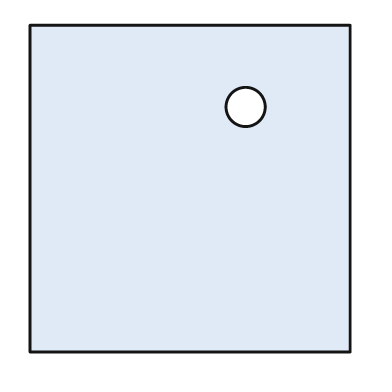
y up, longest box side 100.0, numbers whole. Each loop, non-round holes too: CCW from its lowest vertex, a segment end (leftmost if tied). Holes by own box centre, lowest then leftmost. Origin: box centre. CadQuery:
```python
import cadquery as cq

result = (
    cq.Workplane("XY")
    .moveTo(-49.0, -50.0)
    .lineTo(49.0, -50.0)
    .lineTo(49.0, 50.0)
    .lineTo(-49.0, 50.0)
    .close()
    .moveTo(17.0, 25.0)
    .circle(6.0)
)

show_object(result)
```